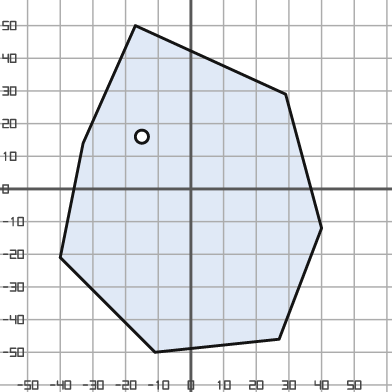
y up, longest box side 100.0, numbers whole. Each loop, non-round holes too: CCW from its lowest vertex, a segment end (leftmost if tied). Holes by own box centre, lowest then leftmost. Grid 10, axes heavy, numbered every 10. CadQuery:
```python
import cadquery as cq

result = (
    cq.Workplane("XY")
    .moveTo(-11.0, -50.0)
    .lineTo(27.0, -46.0)
    .lineTo(40.0, -12.0)
    .lineTo(29.0, 29.0)
    .lineTo(-17.0, 50.0)
    .lineTo(-33.0, 14.0)
    .lineTo(-40.0, -21.0)
    .close()
    .moveTo(-15.0, 16.0)
    .circle(2.0)
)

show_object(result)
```